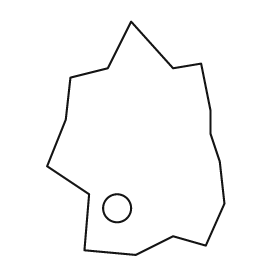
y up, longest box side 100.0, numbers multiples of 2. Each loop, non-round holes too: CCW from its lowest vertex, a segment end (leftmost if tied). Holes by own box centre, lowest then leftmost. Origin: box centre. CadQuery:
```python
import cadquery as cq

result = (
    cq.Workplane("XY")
    .moveTo(0.0, -50.0)
    .lineTo(16.0, -42.0)
    .lineTo(30.0, -46.0)
    .lineTo(38.0, -28.0)
    .lineTo(36.0, -10.0)
    .lineTo(32.0, 2.0)
    .lineTo(32.0, 12.0)
    .lineTo(28.0, 32.0)
    .lineTo(16.0, 30.0)
    .lineTo(-2.0, 50.0)
    .lineTo(-12.0, 30.0)
    .lineTo(-28.0, 26.0)
    .lineTo(-30.0, 8.0)
    .lineTo(-38.0, -12.0)
    .lineTo(-20.0, -24.0)
    .lineTo(-22.0, -48.0)
    .close()
    .moveTo(-8.0, -30.0)
    .circle(6.0)
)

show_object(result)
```